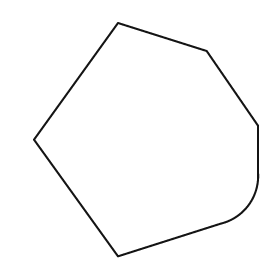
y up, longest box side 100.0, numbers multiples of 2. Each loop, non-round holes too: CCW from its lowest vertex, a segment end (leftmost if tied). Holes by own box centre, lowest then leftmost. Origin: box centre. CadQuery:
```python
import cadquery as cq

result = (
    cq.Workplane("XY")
    .moveTo(-12.0, -50.0)
    .lineTo(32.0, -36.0)
    .threePointArc((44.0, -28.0), (48.0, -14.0))
    .lineTo(48.0, 6.0)
    .lineTo(26.0, 38.0)
    .lineTo(-12.0, 50.0)
    .lineTo(-48.0, 0.0)
    .close()
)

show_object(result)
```